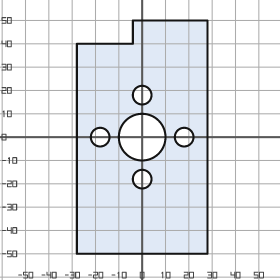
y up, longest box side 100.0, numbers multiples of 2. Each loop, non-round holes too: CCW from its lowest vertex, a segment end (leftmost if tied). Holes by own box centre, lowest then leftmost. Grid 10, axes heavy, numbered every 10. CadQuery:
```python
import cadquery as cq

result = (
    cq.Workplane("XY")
    .moveTo(-28.0, -50.0)
    .lineTo(28.0, -50.0)
    .lineTo(28.0, 50.0)
    .lineTo(-4.0, 50.0)
    .lineTo(-4.0, 40.0)
    .lineTo(-28.0, 40.0)
    .close()
    .moveTo(0.0, -18.0)
    .circle(4.0)
    .moveTo(-18.0, 0.0)
    .circle(4.0)
    .moveTo(0.0, 0.0)
    .circle(10.0)
    .moveTo(18.0, 0.0)
    .circle(4.0)
    .moveTo(0.0, 18.0)
    .circle(4.0)
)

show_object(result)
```